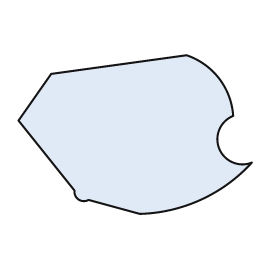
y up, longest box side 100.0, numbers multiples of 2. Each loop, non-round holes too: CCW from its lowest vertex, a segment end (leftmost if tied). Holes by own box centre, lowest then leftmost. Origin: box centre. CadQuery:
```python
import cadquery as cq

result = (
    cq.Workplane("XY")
    .moveTo(2.0, -34.0)
    .threePointArc((28.0, -28.0), (50.0, -12.0))
    .threePointArc((36.0, -6.0), (42.0, 8.0))
    .threePointArc((36.0, 24.0), (22.0, 34.0))
    .lineTo(-36.0, 26.0)
    .lineTo(-50.0, 6.0)
    .lineTo(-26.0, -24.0)
    .threePointArc((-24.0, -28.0), (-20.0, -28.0))
    .close()
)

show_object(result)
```